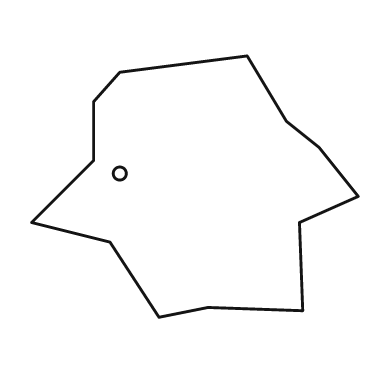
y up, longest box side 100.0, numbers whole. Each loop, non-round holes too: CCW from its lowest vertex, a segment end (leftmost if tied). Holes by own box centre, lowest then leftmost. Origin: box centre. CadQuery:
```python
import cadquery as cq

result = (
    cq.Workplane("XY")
    .moveTo(-11.0, -40.0)
    .lineTo(4.0, -37.0)
    .lineTo(33.0, -38.0)
    .lineTo(32.0, -11.0)
    .lineTo(50.0, -3.0)
    .lineTo(38.0, 12.0)
    .lineTo(28.0, 20.0)
    .lineTo(16.0, 40.0)
    .lineTo(-23.0, 35.0)
    .lineTo(-31.0, 26.0)
    .lineTo(-31.0, 8.0)
    .lineTo(-50.0, -11.0)
    .lineTo(-26.0, -17.0)
    .close()
    .moveTo(-23.0, 4.0)
    .circle(2.0)
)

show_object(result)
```